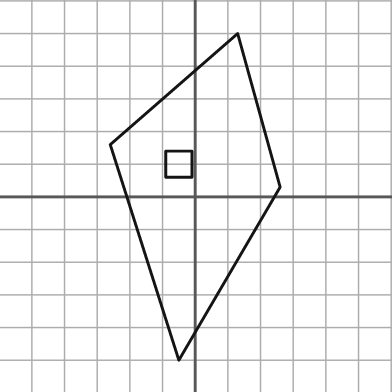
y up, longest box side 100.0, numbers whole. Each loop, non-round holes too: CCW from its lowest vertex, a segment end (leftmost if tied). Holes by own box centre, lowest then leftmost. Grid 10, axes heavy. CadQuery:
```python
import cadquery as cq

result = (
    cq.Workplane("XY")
    .moveTo(-5.0, -50.0)
    .lineTo(26.0, 3.0)
    .lineTo(13.0, 50.0)
    .lineTo(-26.0, 16.0)
    .close()
    .moveTo(-9.0, 6.0)
    .lineTo(-1.0, 6.0)
    .lineTo(-1.0, 14.0)
    .lineTo(-9.0, 14.0)
    .close()
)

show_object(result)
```